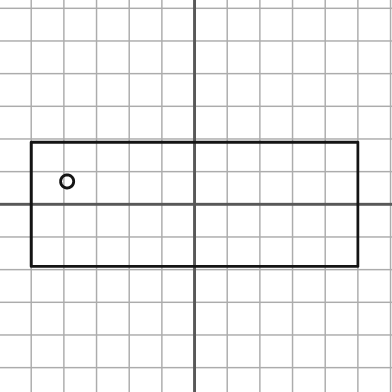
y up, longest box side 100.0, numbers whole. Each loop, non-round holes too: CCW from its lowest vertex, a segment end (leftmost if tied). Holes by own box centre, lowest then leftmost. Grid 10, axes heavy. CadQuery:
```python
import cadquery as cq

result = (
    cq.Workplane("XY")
    .moveTo(-50.0, -19.0)
    .lineTo(50.0, -19.0)
    .lineTo(50.0, 19.0)
    .lineTo(-50.0, 19.0)
    .close()
    .moveTo(-39.0, 7.0)
    .circle(2.0)
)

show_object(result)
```